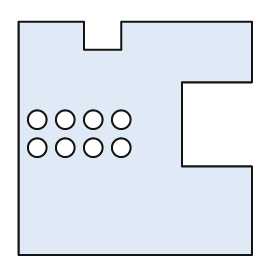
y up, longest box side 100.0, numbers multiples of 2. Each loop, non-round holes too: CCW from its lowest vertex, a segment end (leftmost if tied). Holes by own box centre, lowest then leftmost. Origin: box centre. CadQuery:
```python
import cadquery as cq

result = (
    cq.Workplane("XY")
    .moveTo(-50.0, -50.0)
    .lineTo(50.0, -50.0)
    .lineTo(50.0, -12.0)
    .lineTo(20.0, -12.0)
    .lineTo(20.0, 24.0)
    .lineTo(50.0, 24.0)
    .lineTo(50.0, 50.0)
    .lineTo(-6.0, 50.0)
    .lineTo(-6.0, 38.0)
    .lineTo(-22.0, 38.0)
    .lineTo(-22.0, 50.0)
    .lineTo(-50.0, 50.0)
    .close()
    .moveTo(-42.0, -4.0)
    .circle(4.0)
    .moveTo(-30.0, -4.0)
    .circle(4.0)
    .moveTo(-18.0, -4.0)
    .circle(4.0)
    .moveTo(-6.0, -4.0)
    .circle(4.0)
    .moveTo(-42.0, 8.0)
    .circle(4.0)
    .moveTo(-30.0, 8.0)
    .circle(4.0)
    .moveTo(-18.0, 8.0)
    .circle(4.0)
    .moveTo(-6.0, 8.0)
    .circle(4.0)
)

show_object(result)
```